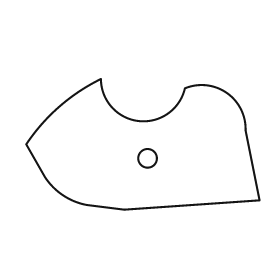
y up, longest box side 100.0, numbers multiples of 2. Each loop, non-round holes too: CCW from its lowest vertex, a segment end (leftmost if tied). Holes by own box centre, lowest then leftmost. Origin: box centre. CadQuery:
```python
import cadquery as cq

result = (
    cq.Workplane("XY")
    .moveTo(-8.0, -28.0)
    .lineTo(50.0, -24.0)
    .lineTo(44.0, 6.0)
    .threePointArc((36.0, 22.0), (18.0, 24.0))
    .threePointArc((-2.0, 10.0), (-18.0, 28.0))
    .threePointArc((-36.0, 16.0), (-50.0, 0.0))
    .lineTo(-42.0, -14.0)
    .threePointArc((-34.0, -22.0), (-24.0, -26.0))
    .close()
    .moveTo(2.0, -6.0)
    .circle(4.0)
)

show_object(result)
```